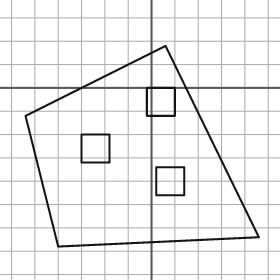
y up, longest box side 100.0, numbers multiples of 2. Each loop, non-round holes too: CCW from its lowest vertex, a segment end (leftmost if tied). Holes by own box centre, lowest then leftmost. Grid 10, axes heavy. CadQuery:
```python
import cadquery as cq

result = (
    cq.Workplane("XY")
    .moveTo(-40.0, -68.0)
    .lineTo(46.0, -64.0)
    .lineTo(6.0, 18.0)
    .lineTo(-54.0, -12.0)
    .close()
    .moveTo(2.0, -46.0)
    .lineTo(14.0, -46.0)
    .lineTo(14.0, -34.0)
    .lineTo(2.0, -34.0)
    .close()
    .moveTo(-30.0, -32.0)
    .lineTo(-18.0, -32.0)
    .lineTo(-18.0, -20.0)
    .lineTo(-30.0, -20.0)
    .close()
    .moveTo(-2.0, -12.0)
    .lineTo(10.0, -12.0)
    .lineTo(10.0, 0.0)
    .lineTo(-2.0, 0.0)
    .close()
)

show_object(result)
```